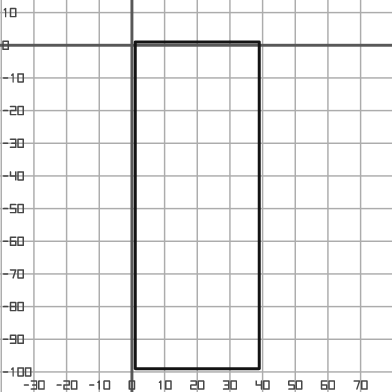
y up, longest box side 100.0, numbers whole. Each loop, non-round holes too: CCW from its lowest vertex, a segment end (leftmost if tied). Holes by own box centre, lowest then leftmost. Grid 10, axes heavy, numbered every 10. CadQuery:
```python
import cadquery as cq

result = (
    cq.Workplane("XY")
    .moveTo(1.0, -99.0)
    .lineTo(39.0, -99.0)
    .lineTo(39.0, 1.0)
    .lineTo(1.0, 1.0)
    .close()
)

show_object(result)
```